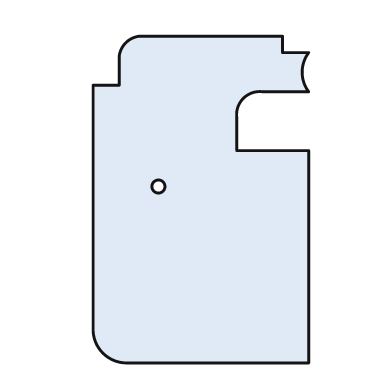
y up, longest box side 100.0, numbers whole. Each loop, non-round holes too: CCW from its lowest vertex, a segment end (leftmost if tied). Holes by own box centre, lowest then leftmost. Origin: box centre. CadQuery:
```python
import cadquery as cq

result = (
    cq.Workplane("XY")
    .moveTo(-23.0, -50.0)
    .lineTo(33.0, -50.0)
    .lineTo(33.0, 15.0)
    .lineTo(11.0, 15.0)
    .lineTo(11.0, 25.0)
    .threePointArc((13.0, 31.0), (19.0, 33.0))
    .lineTo(33.0, 33.0)
    .threePointArc((31.0, 39.0), (33.0, 45.0))
    .lineTo(25.0, 45.0)
    .lineTo(25.0, 50.0)
    .lineTo(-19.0, 50.0)
    .threePointArc((-23.0, 48.0), (-25.0, 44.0))
    .lineTo(-25.0, 35.0)
    .lineTo(-33.0, 35.0)
    .lineTo(-33.0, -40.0)
    .threePointArc((-30.0, -47.0), (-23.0, -50.0))
    .close()
    .moveTo(-13.0, 4.0)
    .circle(2.0)
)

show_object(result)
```